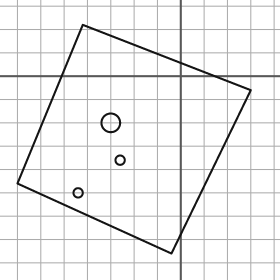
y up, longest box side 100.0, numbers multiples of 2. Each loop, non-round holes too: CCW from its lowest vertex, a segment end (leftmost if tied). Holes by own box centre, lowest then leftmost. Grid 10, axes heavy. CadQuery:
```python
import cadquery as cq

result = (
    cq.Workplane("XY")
    .moveTo(-4.0, -76.0)
    .lineTo(30.0, -6.0)
    .lineTo(-42.0, 22.0)
    .lineTo(-70.0, -46.0)
    .close()
    .moveTo(-44.0, -50.0)
    .circle(2.0)
    .moveTo(-26.0, -36.0)
    .circle(2.0)
    .moveTo(-30.0, -20.0)
    .circle(4.0)
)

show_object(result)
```